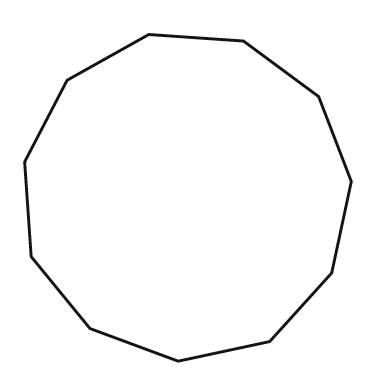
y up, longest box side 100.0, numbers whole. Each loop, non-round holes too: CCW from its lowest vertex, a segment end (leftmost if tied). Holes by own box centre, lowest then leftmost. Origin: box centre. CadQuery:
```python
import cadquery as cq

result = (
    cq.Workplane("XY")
    .moveTo(-3.0, -50.0)
    .lineTo(25.0, -44.0)
    .lineTo(44.0, -23.0)
    .lineTo(50.0, 5.0)
    .lineTo(40.0, 31.0)
    .lineTo(17.0, 48.0)
    .lineTo(-12.0, 50.0)
    .lineTo(-37.0, 36.0)
    .lineTo(-50.0, 11.0)
    .lineTo(-48.0, -18.0)
    .lineTo(-30.0, -40.0)
    .close()
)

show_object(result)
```